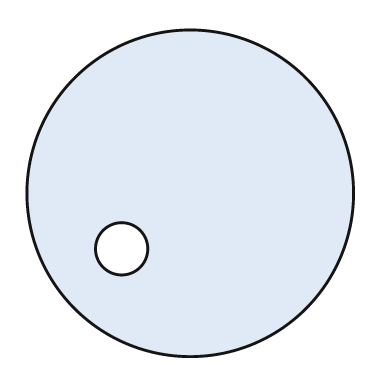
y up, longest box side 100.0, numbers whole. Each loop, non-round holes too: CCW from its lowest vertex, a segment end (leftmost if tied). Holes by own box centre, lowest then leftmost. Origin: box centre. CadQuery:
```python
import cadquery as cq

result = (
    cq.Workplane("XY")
    .moveTo(0.0, 0.0)
    .circle(50.0)
    .moveTo(-21.0, -17.0)
    .circle(8.0)
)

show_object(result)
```